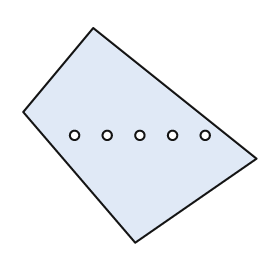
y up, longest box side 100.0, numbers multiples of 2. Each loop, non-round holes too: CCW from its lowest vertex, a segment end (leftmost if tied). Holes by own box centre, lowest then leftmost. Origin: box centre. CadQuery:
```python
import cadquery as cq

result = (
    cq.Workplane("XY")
    .moveTo(-2.0, -46.0)
    .lineTo(50.0, -10.0)
    .lineTo(-20.0, 46.0)
    .lineTo(-50.0, 10.0)
    .close()
    .moveTo(-28.0, 0.0)
    .circle(2.0)
    .moveTo(-14.0, 0.0)
    .circle(2.0)
    .moveTo(0.0, 0.0)
    .circle(2.0)
    .moveTo(14.0, 0.0)
    .circle(2.0)
    .moveTo(28.0, 0.0)
    .circle(2.0)
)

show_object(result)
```